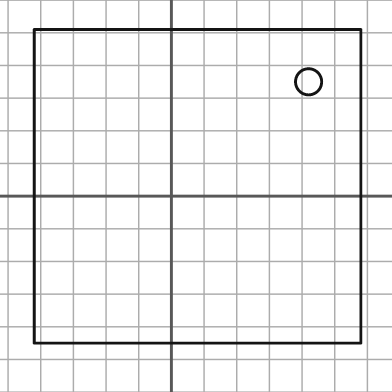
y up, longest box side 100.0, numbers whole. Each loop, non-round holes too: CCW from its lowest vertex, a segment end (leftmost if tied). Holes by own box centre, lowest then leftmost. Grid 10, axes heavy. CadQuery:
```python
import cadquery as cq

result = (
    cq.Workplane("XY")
    .moveTo(-42.0, -45.0)
    .lineTo(58.0, -45.0)
    .lineTo(58.0, 51.0)
    .lineTo(-42.0, 51.0)
    .close()
    .moveTo(42.0, 35.0)
    .circle(4.0)
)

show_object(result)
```